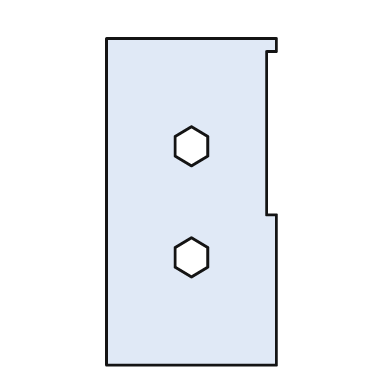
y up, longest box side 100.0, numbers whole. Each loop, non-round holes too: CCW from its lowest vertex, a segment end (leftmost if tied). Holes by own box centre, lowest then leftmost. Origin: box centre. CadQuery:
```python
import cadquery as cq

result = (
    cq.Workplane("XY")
    .moveTo(-26.0, -50.0)
    .lineTo(26.0, -50.0)
    .lineTo(26.0, -4.0)
    .lineTo(23.0, -4.0)
    .lineTo(23.0, 46.0)
    .lineTo(26.0, 46.0)
    .lineTo(26.0, 50.0)
    .lineTo(-26.0, 50.0)
    .close()
    .moveTo(0.0, -23.0)
    .lineTo(5.0, -20.0)
    .lineTo(5.0, -14.0)
    .lineTo(0.0, -11.0)
    .lineTo(-5.0, -14.0)
    .lineTo(-5.0, -20.0)
    .close()
    .moveTo(0.0, 11.0)
    .lineTo(5.0, 14.0)
    .lineTo(5.0, 20.0)
    .lineTo(0.0, 23.0)
    .lineTo(-5.0, 20.0)
    .lineTo(-5.0, 14.0)
    .close()
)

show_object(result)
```